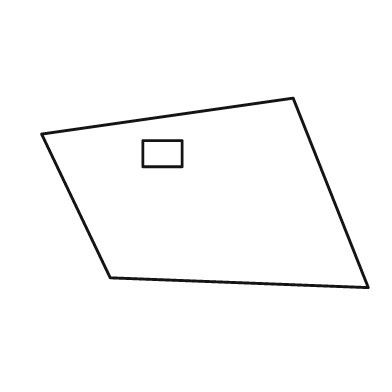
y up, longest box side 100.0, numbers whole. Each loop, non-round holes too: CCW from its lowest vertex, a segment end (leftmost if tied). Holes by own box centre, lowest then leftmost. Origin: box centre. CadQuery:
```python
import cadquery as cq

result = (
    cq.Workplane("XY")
    .moveTo(50.0, -29.0)
    .lineTo(27.0, 29.0)
    .lineTo(-50.0, 18.0)
    .lineTo(-29.0, -26.0)
    .close()
    .moveTo(-19.0, 8.0)
    .lineTo(-7.0, 8.0)
    .lineTo(-7.0, 16.0)
    .lineTo(-19.0, 16.0)
    .close()
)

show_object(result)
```